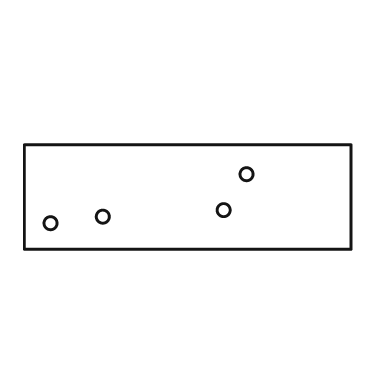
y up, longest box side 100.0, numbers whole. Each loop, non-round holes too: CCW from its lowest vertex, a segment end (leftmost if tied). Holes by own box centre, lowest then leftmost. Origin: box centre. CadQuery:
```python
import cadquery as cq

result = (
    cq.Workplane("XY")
    .moveTo(-50.0, -16.0)
    .lineTo(50.0, -16.0)
    .lineTo(50.0, 16.0)
    .lineTo(-50.0, 16.0)
    .close()
    .moveTo(-42.0, -8.0)
    .circle(2.0)
    .moveTo(-26.0, -6.0)
    .circle(2.0)
    .moveTo(11.0, -4.0)
    .circle(2.0)
    .moveTo(18.0, 7.0)
    .circle(2.0)
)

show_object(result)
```